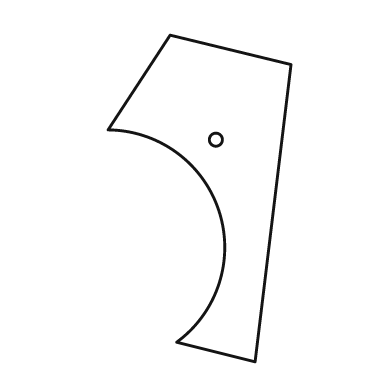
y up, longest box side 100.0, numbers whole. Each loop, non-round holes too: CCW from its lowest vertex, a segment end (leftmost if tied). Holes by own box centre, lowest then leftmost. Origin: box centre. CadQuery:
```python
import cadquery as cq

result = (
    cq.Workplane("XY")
    .moveTo(17.0, -50.0)
    .lineTo(28.0, 41.0)
    .lineTo(-9.0, 50.0)
    .lineTo(-28.0, 21.0)
    .threePointArc((6.0, -4.0), (-7.0, -44.0))
    .close()
    .moveTo(5.0, 18.0)
    .circle(2.0)
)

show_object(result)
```